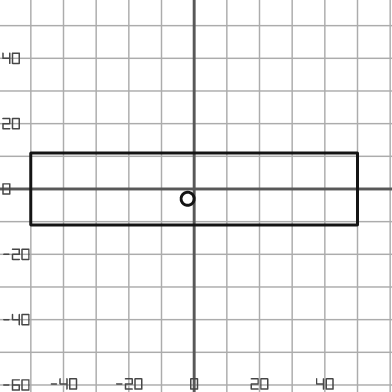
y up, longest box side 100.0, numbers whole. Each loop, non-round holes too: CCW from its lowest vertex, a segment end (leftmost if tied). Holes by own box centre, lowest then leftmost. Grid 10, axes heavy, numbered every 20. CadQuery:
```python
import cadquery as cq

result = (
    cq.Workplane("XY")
    .moveTo(-50.0, -11.0)
    .lineTo(50.0, -11.0)
    .lineTo(50.0, 11.0)
    .lineTo(-50.0, 11.0)
    .close()
    .moveTo(-2.0, -3.0)
    .circle(2.0)
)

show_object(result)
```